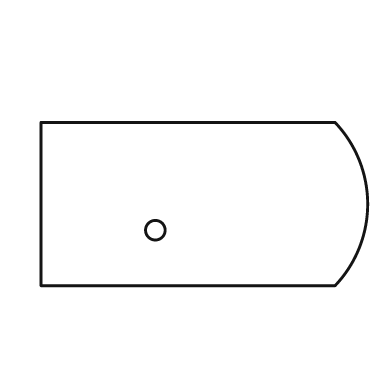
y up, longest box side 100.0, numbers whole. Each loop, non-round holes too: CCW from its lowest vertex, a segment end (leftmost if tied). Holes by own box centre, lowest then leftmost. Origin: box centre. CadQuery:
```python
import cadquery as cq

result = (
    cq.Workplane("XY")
    .moveTo(-50.0, -25.0)
    .lineTo(40.0, -25.0)
    .threePointArc((50.0, 0.0), (40.0, 25.0))
    .lineTo(-50.0, 25.0)
    .close()
    .moveTo(-15.0, -8.0)
    .circle(3.0)
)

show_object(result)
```